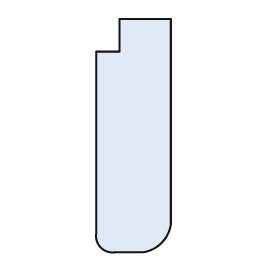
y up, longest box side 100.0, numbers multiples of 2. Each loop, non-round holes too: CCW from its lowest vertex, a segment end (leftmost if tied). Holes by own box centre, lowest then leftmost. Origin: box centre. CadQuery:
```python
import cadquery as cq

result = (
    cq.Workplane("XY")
    .moveTo(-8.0, -50.0)
    .lineTo(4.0, -50.0)
    .threePointArc((12.0, -46.0), (16.0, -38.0))
    .lineTo(16.0, 50.0)
    .lineTo(-6.0, 50.0)
    .lineTo(-6.0, 36.0)
    .lineTo(-16.0, 36.0)
    .lineTo(-16.0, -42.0)
    .threePointArc((-14.0, -48.0), (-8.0, -50.0))
    .close()
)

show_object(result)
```